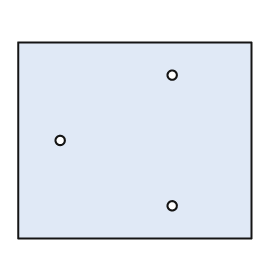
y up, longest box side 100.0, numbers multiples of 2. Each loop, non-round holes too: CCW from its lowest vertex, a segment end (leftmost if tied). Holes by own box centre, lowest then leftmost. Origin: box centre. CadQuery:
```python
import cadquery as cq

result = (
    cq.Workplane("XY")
    .moveTo(-50.0, -42.0)
    .lineTo(50.0, -42.0)
    .lineTo(50.0, 42.0)
    .lineTo(-50.0, 42.0)
    .close()
    .moveTo(16.0, -28.0)
    .circle(2.0)
    .moveTo(-32.0, 0.0)
    .circle(2.0)
    .moveTo(16.0, 28.0)
    .circle(2.0)
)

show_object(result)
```